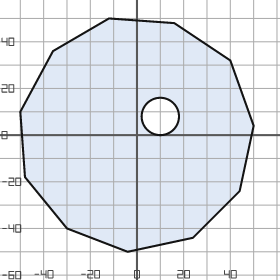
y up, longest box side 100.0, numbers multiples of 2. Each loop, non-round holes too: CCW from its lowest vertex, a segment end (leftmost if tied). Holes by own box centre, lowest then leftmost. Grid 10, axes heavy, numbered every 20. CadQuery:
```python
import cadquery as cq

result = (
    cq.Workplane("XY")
    .moveTo(-4.0, -50.0)
    .lineTo(24.0, -44.0)
    .lineTo(44.0, -24.0)
    .lineTo(50.0, 4.0)
    .lineTo(40.0, 32.0)
    .lineTo(16.0, 48.0)
    .lineTo(-12.0, 50.0)
    .lineTo(-36.0, 36.0)
    .lineTo(-50.0, 10.0)
    .lineTo(-48.0, -18.0)
    .lineTo(-30.0, -40.0)
    .close()
    .moveTo(10.0, 8.0)
    .circle(8.0)
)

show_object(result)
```